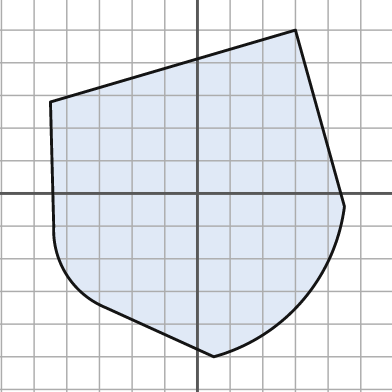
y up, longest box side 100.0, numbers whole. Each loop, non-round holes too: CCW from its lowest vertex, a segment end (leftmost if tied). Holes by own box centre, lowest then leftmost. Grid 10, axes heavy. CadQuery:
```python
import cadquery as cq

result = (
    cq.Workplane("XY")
    .moveTo(5.0, -50.0)
    .threePointArc((32.0, -33.0), (45.0, -4.0))
    .lineTo(30.0, 50.0)
    .lineTo(-45.0, 28.0)
    .lineTo(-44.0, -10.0)
    .threePointArc((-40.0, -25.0), (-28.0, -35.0))
    .close()
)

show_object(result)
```